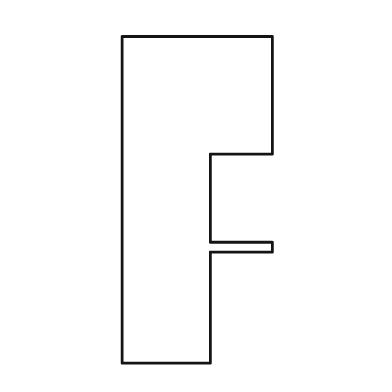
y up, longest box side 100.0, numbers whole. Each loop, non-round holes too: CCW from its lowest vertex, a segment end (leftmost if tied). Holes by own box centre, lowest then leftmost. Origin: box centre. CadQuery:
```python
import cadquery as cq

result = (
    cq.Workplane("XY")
    .moveTo(-23.0, -50.0)
    .lineTo(4.0, -50.0)
    .lineTo(4.0, -16.0)
    .lineTo(23.0, -16.0)
    .lineTo(23.0, -13.0)
    .lineTo(4.0, -13.0)
    .lineTo(4.0, 14.0)
    .lineTo(23.0, 14.0)
    .lineTo(23.0, 50.0)
    .lineTo(-23.0, 50.0)
    .close()
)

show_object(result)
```